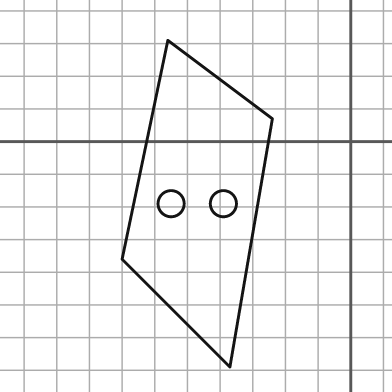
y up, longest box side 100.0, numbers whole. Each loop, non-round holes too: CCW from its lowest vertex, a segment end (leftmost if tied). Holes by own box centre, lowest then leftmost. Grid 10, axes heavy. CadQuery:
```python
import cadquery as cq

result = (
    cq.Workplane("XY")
    .moveTo(-37.0, -69.0)
    .lineTo(-24.0, 7.0)
    .lineTo(-56.0, 31.0)
    .lineTo(-70.0, -36.0)
    .close()
    .moveTo(-55.0, -19.0)
    .circle(4.0)
    .moveTo(-39.0, -19.0)
    .circle(4.0)
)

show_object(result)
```